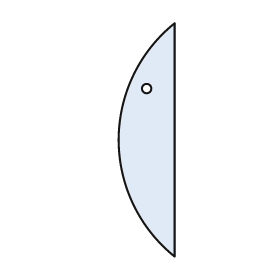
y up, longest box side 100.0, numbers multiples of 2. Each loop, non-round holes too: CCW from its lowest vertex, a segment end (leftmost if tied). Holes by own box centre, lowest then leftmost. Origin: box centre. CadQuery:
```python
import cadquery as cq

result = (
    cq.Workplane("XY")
    .moveTo(12.0, -50.0)
    .lineTo(12.0, 50.0)
    .threePointArc((-12.0, 0.0), (12.0, -50.0))
    .close()
    .moveTo(0.0, 22.0)
    .circle(2.0)
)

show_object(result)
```